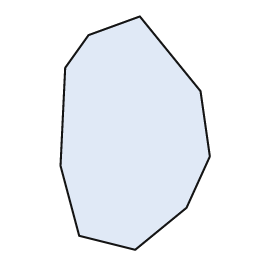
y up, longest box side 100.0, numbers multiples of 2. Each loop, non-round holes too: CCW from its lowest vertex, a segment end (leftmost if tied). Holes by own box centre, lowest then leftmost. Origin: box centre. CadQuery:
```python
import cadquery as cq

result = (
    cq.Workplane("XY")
    .moveTo(0.0, -50.0)
    .lineTo(22.0, -32.0)
    .lineTo(32.0, -10.0)
    .lineTo(28.0, 18.0)
    .lineTo(2.0, 50.0)
    .lineTo(-20.0, 42.0)
    .lineTo(-30.0, 28.0)
    .lineTo(-32.0, -14.0)
    .lineTo(-24.0, -44.0)
    .close()
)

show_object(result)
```